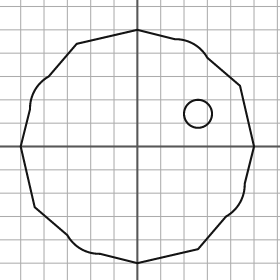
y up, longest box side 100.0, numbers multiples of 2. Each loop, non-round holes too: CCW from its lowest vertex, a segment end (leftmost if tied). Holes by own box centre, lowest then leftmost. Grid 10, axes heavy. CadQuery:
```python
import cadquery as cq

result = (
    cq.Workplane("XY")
    .moveTo(0.0, -50.0)
    .lineTo(26.0, -44.0)
    .lineTo(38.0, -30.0)
    .threePointArc((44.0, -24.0), (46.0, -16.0))
    .lineTo(50.0, 0.0)
    .lineTo(44.0, 26.0)
    .lineTo(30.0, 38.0)
    .threePointArc((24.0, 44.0), (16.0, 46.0))
    .lineTo(0.0, 50.0)
    .lineTo(-26.0, 44.0)
    .lineTo(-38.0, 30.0)
    .threePointArc((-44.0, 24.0), (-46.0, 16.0))
    .lineTo(-50.0, 0.0)
    .lineTo(-44.0, -26.0)
    .lineTo(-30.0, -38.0)
    .threePointArc((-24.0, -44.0), (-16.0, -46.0))
    .close()
    .moveTo(26.0, 14.0)
    .circle(6.0)
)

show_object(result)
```